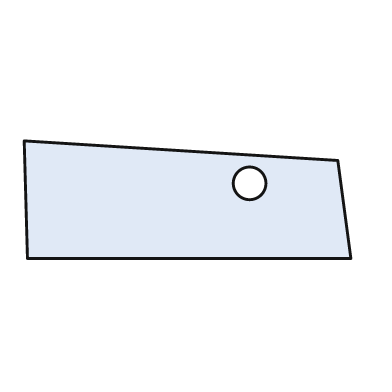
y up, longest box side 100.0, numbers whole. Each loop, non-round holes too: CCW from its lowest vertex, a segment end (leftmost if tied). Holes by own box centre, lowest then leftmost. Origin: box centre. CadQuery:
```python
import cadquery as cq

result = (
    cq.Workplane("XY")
    .moveTo(-49.0, -18.0)
    .lineTo(50.0, -18.0)
    .lineTo(46.0, 12.0)
    .lineTo(-50.0, 18.0)
    .close()
    .moveTo(19.0, 5.0)
    .circle(5.0)
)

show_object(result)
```